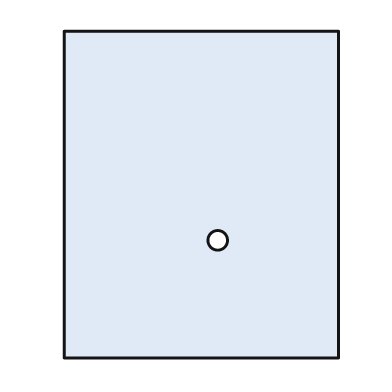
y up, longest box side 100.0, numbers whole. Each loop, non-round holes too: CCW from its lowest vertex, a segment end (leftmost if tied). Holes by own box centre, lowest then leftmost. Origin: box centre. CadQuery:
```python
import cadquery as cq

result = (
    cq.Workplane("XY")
    .moveTo(-42.0, -50.0)
    .lineTo(42.0, -50.0)
    .lineTo(42.0, 50.0)
    .lineTo(-42.0, 50.0)
    .close()
    .moveTo(5.0, -14.0)
    .circle(3.0)
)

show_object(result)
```